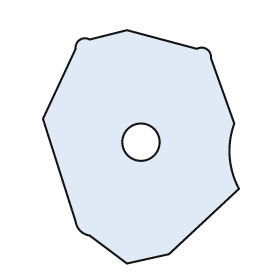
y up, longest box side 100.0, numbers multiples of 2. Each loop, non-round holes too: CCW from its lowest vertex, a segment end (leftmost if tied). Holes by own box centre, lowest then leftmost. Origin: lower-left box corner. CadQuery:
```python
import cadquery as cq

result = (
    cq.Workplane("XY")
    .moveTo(36.0, 0.0)
    .lineTo(54.0, 4.0)
    .lineTo(84.0, 32.0)
    .threePointArc((80.0, 46.0), (82.0, 60.0))
    .lineTo(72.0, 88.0)
    .threePointArc((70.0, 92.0), (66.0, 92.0))
    .lineTo(36.0, 100.0)
    .lineTo(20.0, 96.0)
    .threePointArc((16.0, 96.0), (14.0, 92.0))
    .lineTo(0.0, 62.0)
    .lineTo(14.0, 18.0)
    .threePointArc((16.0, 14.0), (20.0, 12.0))
    .close()
    .moveTo(42.0, 52.0)
    .circle(8.0)
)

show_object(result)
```